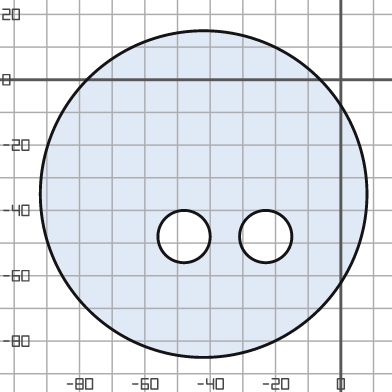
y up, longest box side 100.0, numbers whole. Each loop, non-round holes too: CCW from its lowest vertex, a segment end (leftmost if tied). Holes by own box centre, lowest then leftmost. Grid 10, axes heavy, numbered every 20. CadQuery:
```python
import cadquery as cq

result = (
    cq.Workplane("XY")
    .moveTo(-42.0, -35.0)
    .circle(50.0)
    .moveTo(-48.0, -48.0)
    .circle(8.0)
    .moveTo(-23.0, -48.0)
    .circle(8.0)
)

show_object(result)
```